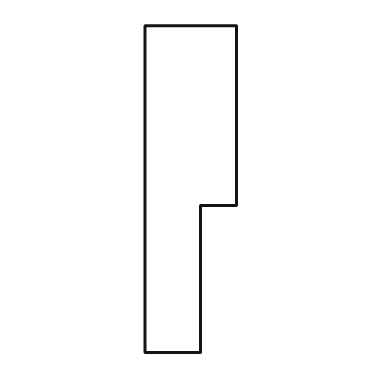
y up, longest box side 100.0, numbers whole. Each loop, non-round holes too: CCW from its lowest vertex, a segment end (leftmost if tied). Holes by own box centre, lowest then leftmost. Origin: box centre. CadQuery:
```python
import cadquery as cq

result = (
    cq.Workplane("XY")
    .moveTo(-14.0, -50.0)
    .lineTo(3.0, -50.0)
    .lineTo(3.0, -5.0)
    .lineTo(14.0, -5.0)
    .lineTo(14.0, 50.0)
    .lineTo(-14.0, 50.0)
    .close()
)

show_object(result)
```